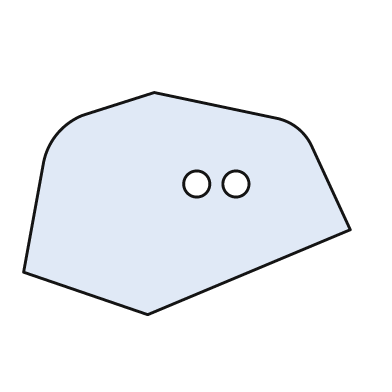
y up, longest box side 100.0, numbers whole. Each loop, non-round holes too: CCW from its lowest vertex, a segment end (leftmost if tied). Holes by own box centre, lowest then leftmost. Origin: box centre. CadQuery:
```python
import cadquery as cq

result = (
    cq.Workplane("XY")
    .moveTo(-12.0, -34.0)
    .lineTo(50.0, -8.0)
    .lineTo(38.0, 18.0)
    .threePointArc((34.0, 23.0), (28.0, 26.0))
    .lineTo(-10.0, 34.0)
    .lineTo(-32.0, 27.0)
    .threePointArc((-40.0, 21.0), (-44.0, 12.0))
    .lineTo(-50.0, -21.0)
    .close()
    .moveTo(3.0, 6.0)
    .circle(4.0)
    .moveTo(15.0, 6.0)
    .circle(4.0)
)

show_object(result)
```